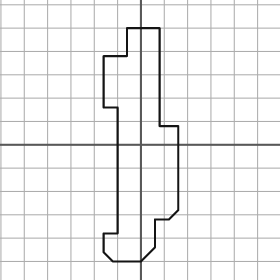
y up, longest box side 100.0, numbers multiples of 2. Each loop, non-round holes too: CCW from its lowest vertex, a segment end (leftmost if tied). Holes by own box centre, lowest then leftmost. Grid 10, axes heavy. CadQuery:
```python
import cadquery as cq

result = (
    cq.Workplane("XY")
    .moveTo(-12.0, -50.0)
    .lineTo(0.0, -50.0)
    .lineTo(6.0, -44.0)
    .lineTo(6.0, -32.0)
    .lineTo(12.0, -32.0)
    .lineTo(16.0, -28.0)
    .lineTo(16.0, 8.0)
    .lineTo(8.0, 8.0)
    .lineTo(8.0, 50.0)
    .lineTo(-6.0, 50.0)
    .lineTo(-6.0, 38.0)
    .lineTo(-16.0, 38.0)
    .lineTo(-16.0, 16.0)
    .lineTo(-10.0, 16.0)
    .lineTo(-10.0, -38.0)
    .lineTo(-16.0, -38.0)
    .lineTo(-16.0, -46.0)
    .close()
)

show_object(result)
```